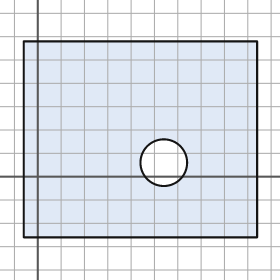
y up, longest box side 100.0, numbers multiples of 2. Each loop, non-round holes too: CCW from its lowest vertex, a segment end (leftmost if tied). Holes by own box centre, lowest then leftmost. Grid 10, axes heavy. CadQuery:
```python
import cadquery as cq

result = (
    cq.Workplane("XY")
    .moveTo(-6.0, -26.0)
    .lineTo(94.0, -26.0)
    .lineTo(94.0, 58.0)
    .lineTo(-6.0, 58.0)
    .close()
    .moveTo(54.0, 6.0)
    .circle(10.0)
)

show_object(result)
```